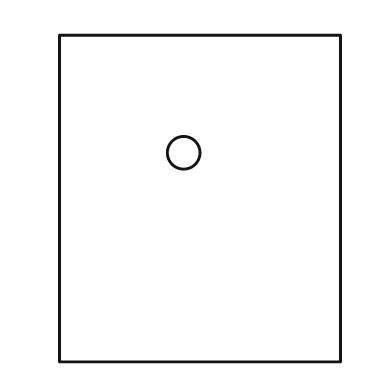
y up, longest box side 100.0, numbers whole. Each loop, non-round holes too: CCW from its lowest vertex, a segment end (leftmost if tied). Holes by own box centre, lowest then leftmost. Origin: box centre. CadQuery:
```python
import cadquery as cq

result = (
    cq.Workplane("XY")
    .moveTo(-43.0, -50.0)
    .lineTo(43.0, -50.0)
    .lineTo(43.0, 50.0)
    .lineTo(-43.0, 50.0)
    .close()
    .moveTo(-5.0, 14.0)
    .circle(5.0)
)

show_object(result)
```